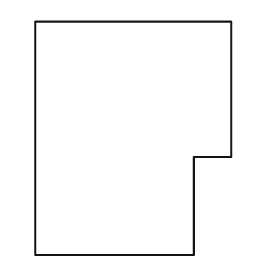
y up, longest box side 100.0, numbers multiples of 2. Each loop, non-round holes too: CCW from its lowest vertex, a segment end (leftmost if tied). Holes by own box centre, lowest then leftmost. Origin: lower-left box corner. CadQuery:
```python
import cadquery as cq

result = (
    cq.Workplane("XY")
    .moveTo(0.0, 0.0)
    .lineTo(68.0, 0.0)
    .lineTo(68.0, 42.0)
    .lineTo(84.0, 42.0)
    .lineTo(84.0, 100.0)
    .lineTo(0.0, 100.0)
    .close()
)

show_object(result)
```